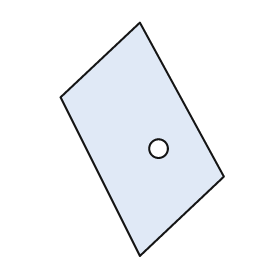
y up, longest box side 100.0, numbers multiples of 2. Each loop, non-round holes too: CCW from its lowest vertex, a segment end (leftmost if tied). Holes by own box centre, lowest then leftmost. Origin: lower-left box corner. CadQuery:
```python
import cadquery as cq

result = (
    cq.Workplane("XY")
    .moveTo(34.0, 0.0)
    .lineTo(70.0, 34.0)
    .lineTo(34.0, 100.0)
    .lineTo(0.0, 68.0)
    .close()
    .moveTo(42.0, 46.0)
    .circle(4.0)
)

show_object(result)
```